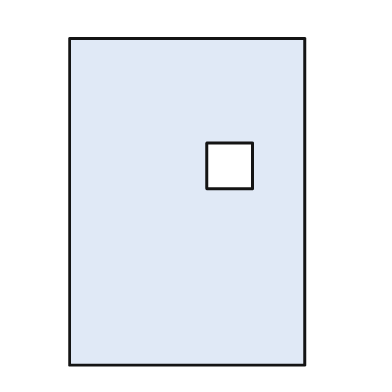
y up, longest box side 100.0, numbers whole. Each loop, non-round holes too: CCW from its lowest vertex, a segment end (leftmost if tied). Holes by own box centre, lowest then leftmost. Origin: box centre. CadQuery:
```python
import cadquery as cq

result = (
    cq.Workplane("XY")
    .moveTo(-36.0, -50.0)
    .lineTo(36.0, -50.0)
    .lineTo(36.0, 50.0)
    .lineTo(-36.0, 50.0)
    .close()
    .moveTo(6.0, 4.0)
    .lineTo(20.0, 4.0)
    .lineTo(20.0, 18.0)
    .lineTo(6.0, 18.0)
    .close()
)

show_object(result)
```